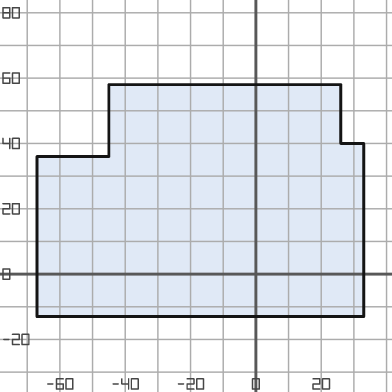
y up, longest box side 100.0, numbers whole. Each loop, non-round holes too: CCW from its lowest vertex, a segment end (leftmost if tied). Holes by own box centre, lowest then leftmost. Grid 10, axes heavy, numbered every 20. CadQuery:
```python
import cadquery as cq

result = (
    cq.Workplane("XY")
    .moveTo(-67.0, -13.0)
    .lineTo(33.0, -13.0)
    .lineTo(33.0, 40.0)
    .lineTo(26.0, 40.0)
    .lineTo(26.0, 58.0)
    .lineTo(-45.0, 58.0)
    .lineTo(-45.0, 36.0)
    .lineTo(-67.0, 36.0)
    .close()
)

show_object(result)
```